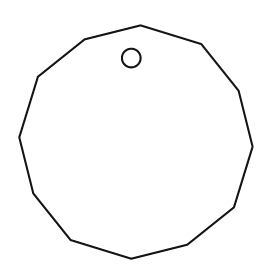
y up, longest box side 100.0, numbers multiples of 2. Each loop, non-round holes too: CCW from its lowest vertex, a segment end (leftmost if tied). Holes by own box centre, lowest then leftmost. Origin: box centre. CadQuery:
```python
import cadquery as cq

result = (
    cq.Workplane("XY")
    .moveTo(-2.0, -50.0)
    .lineTo(22.0, -44.0)
    .lineTo(42.0, -28.0)
    .lineTo(50.0, -2.0)
    .lineTo(44.0, 22.0)
    .lineTo(28.0, 42.0)
    .lineTo(2.0, 50.0)
    .lineTo(-22.0, 44.0)
    .lineTo(-42.0, 28.0)
    .lineTo(-50.0, 2.0)
    .lineTo(-44.0, -22.0)
    .lineTo(-28.0, -42.0)
    .close()
    .moveTo(-2.0, 36.0)
    .circle(4.0)
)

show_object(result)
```